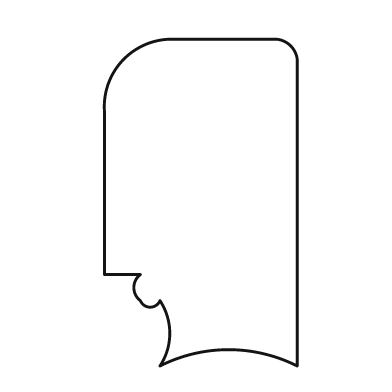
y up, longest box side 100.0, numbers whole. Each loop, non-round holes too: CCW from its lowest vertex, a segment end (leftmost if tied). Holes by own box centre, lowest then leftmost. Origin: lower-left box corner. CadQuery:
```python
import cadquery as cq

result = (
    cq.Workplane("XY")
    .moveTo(17.0, 0.0)
    .threePointArc((38.0, 5.0), (59.0, 0.0))
    .lineTo(59.0, 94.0)
    .threePointArc((57.0, 98.0), (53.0, 100.0))
    .lineTo(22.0, 100.0)
    .threePointArc((6.0, 94.0), (0.0, 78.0))
    .lineTo(0.0, 28.0)
    .lineTo(11.0, 28.0)
    .threePointArc((9.0, 24.0), (11.0, 20.0))
    .threePointArc((14.0, 18.0), (17.0, 20.0))
    .threePointArc((20.0, 10.0), (17.0, 0.0))
    .close()
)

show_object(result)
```